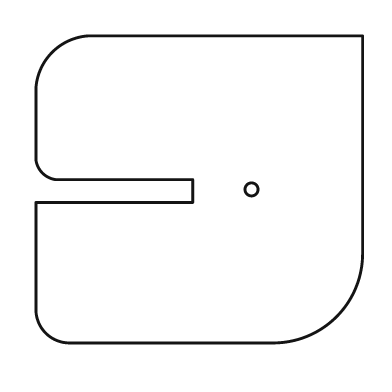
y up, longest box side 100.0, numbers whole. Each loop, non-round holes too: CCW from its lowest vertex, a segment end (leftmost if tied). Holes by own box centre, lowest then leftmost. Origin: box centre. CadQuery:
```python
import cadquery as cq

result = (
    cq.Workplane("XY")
    .moveTo(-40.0, -47.0)
    .lineTo(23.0, -47.0)
    .threePointArc((42.0, -39.0), (50.0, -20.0))
    .lineTo(50.0, 47.0)
    .lineTo(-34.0, 47.0)
    .threePointArc((-45.0, 42.0), (-50.0, 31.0))
    .lineTo(-50.0, 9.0)
    .threePointArc((-48.0, 5.0), (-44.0, 3.0))
    .lineTo(-2.0, 3.0)
    .lineTo(-2.0, -4.0)
    .lineTo(-50.0, -4.0)
    .lineTo(-50.0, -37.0)
    .threePointArc((-47.0, -44.0), (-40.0, -47.0))
    .close()
    .moveTo(16.0, 0.0)
    .circle(2.0)
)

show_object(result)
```